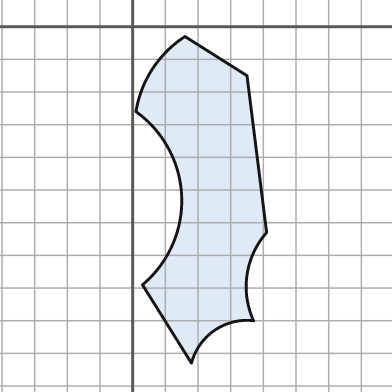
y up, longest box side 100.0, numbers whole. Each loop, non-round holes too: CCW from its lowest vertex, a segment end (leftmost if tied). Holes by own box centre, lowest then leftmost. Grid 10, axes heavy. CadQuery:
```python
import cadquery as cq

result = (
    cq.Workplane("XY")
    .moveTo(18.0, -103.0)
    .threePointArc((25.0, -93.0), (37.0, -90.0))
    .threePointArc((35.0, -76.0), (41.0, -63.0))
    .lineTo(35.0, -15.0)
    .lineTo(16.0, -3.0)
    .threePointArc((6.0, -13.0), (1.0, -26.0))
    .threePointArc((15.0, -52.0), (3.0, -79.0))
    .close()
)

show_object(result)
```